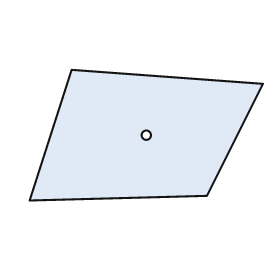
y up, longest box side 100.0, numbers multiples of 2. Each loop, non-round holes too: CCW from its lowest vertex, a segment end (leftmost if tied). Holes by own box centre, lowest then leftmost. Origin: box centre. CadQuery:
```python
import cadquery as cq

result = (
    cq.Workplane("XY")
    .moveTo(-50.0, -28.0)
    .lineTo(26.0, -26.0)
    .lineTo(50.0, 22.0)
    .lineTo(-32.0, 28.0)
    .close()
    .moveTo(0.0, 0.0)
    .circle(2.0)
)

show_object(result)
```